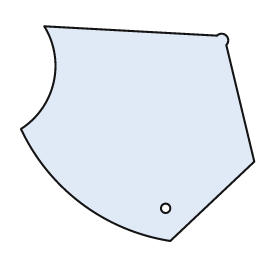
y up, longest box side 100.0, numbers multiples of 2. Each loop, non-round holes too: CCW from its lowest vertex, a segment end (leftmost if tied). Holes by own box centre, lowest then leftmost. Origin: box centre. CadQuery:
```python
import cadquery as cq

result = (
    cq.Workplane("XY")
    .moveTo(14.0, -46.0)
    .lineTo(50.0, -12.0)
    .lineTo(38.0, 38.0)
    .threePointArc((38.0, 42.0), (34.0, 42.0))
    .lineTo(-40.0, 46.0)
    .threePointArc((-36.0, 22.0), (-50.0, 2.0))
    .threePointArc((-24.0, -30.0), (14.0, -46.0))
    .close()
    .moveTo(12.0, -32.0)
    .circle(2.0)
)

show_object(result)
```